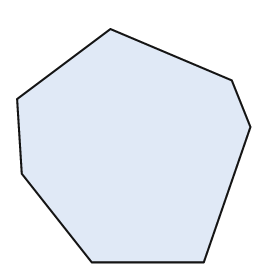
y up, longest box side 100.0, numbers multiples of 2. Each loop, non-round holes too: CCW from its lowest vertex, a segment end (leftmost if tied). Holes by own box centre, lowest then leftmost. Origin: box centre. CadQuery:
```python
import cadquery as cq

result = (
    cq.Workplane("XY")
    .moveTo(-18.0, -50.0)
    .lineTo(30.0, -50.0)
    .lineTo(50.0, 8.0)
    .lineTo(42.0, 28.0)
    .lineTo(-10.0, 50.0)
    .lineTo(-50.0, 20.0)
    .lineTo(-48.0, -12.0)
    .close()
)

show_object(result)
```